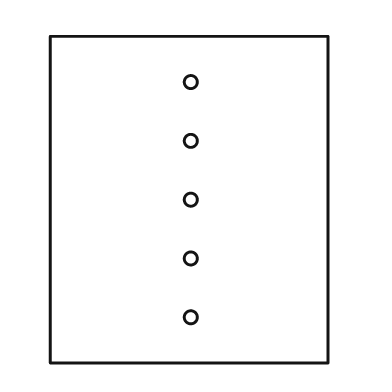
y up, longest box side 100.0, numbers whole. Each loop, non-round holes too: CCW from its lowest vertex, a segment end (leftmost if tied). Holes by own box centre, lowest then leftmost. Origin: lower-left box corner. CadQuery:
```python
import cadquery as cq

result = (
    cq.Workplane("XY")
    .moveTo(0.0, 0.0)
    .lineTo(85.0, 0.0)
    .lineTo(85.0, 100.0)
    .lineTo(0.0, 100.0)
    .close()
    .moveTo(43.0, 14.0)
    .circle(2.0)
    .moveTo(43.0, 32.0)
    .circle(2.0)
    .moveTo(43.0, 50.0)
    .circle(2.0)
    .moveTo(43.0, 68.0)
    .circle(2.0)
    .moveTo(43.0, 86.0)
    .circle(2.0)
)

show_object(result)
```